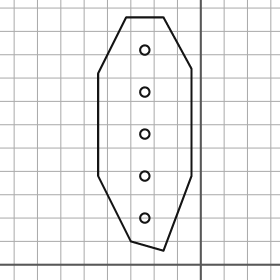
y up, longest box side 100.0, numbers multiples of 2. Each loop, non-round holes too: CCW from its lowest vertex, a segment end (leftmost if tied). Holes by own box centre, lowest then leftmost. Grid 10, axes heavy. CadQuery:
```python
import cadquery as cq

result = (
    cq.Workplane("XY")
    .moveTo(-16.0, 6.0)
    .lineTo(-4.0, 38.0)
    .lineTo(-4.0, 84.0)
    .lineTo(-16.0, 106.0)
    .lineTo(-32.0, 106.0)
    .lineTo(-44.0, 82.0)
    .lineTo(-44.0, 38.0)
    .lineTo(-30.0, 10.0)
    .close()
    .moveTo(-24.0, 20.0)
    .circle(2.0)
    .moveTo(-24.0, 38.0)
    .circle(2.0)
    .moveTo(-24.0, 56.0)
    .circle(2.0)
    .moveTo(-24.0, 74.0)
    .circle(2.0)
    .moveTo(-24.0, 92.0)
    .circle(2.0)
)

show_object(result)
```